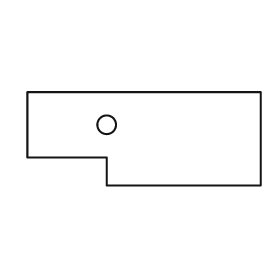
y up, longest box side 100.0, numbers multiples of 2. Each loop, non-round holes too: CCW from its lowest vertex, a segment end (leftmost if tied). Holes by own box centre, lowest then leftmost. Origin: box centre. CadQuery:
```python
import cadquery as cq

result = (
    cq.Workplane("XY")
    .moveTo(-16.0, -20.0)
    .lineTo(50.0, -20.0)
    .lineTo(50.0, 20.0)
    .lineTo(-50.0, 20.0)
    .lineTo(-50.0, -8.0)
    .lineTo(-16.0, -8.0)
    .close()
    .moveTo(-16.0, 6.0)
    .circle(4.0)
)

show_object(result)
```